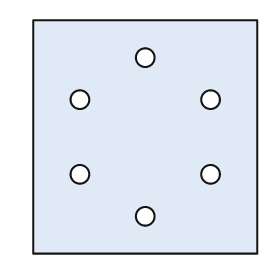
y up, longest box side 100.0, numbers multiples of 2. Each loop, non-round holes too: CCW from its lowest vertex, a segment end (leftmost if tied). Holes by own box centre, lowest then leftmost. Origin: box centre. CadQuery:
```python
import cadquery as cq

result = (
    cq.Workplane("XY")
    .moveTo(-48.0, -50.0)
    .lineTo(48.0, -50.0)
    .lineTo(48.0, 50.0)
    .lineTo(-48.0, 50.0)
    .close()
    .moveTo(0.0, -34.0)
    .circle(4.0)
    .moveTo(-28.0, -16.0)
    .circle(4.0)
    .moveTo(28.0, -16.0)
    .circle(4.0)
    .moveTo(-28.0, 16.0)
    .circle(4.0)
    .moveTo(28.0, 16.0)
    .circle(4.0)
    .moveTo(0.0, 34.0)
    .circle(4.0)
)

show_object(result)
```